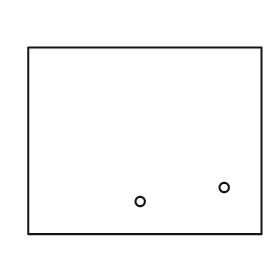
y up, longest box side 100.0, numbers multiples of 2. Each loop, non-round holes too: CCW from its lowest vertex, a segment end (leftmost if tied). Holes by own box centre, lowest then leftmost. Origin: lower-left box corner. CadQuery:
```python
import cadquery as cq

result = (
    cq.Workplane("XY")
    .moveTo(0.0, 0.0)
    .lineTo(100.0, 0.0)
    .lineTo(100.0, 80.0)
    .lineTo(0.0, 80.0)
    .close()
    .moveTo(48.0, 14.0)
    .circle(2.0)
    .moveTo(84.0, 20.0)
    .circle(2.0)
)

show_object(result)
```